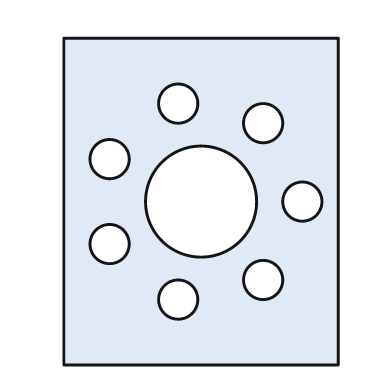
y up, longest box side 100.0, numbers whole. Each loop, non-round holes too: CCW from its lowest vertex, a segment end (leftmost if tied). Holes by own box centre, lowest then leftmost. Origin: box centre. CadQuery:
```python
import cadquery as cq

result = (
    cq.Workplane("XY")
    .moveTo(-42.0, -50.0)
    .lineTo(42.0, -50.0)
    .lineTo(42.0, 50.0)
    .lineTo(-42.0, 50.0)
    .close()
    .moveTo(-7.0, -30.0)
    .circle(6.0)
    .moveTo(19.0, -24.0)
    .circle(6.0)
    .moveTo(-28.0, -13.0)
    .circle(6.0)
    .moveTo(0.0, 0.0)
    .circle(17.0)
    .moveTo(31.0, 0.0)
    .circle(6.0)
    .moveTo(-28.0, 13.0)
    .circle(6.0)
    .moveTo(19.0, 24.0)
    .circle(6.0)
    .moveTo(-7.0, 30.0)
    .circle(6.0)
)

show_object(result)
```